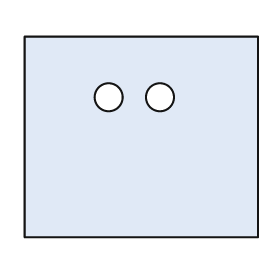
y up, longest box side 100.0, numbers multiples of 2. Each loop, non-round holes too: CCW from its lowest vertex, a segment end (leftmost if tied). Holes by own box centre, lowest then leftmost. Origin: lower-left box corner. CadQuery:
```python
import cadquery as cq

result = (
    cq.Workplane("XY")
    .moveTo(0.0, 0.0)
    .lineTo(100.0, 0.0)
    .lineTo(100.0, 86.0)
    .lineTo(0.0, 86.0)
    .close()
    .moveTo(36.0, 60.0)
    .circle(6.0)
    .moveTo(58.0, 60.0)
    .circle(6.0)
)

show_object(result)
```